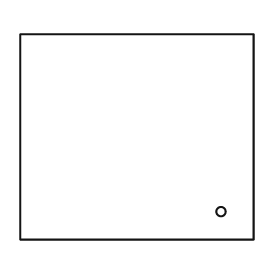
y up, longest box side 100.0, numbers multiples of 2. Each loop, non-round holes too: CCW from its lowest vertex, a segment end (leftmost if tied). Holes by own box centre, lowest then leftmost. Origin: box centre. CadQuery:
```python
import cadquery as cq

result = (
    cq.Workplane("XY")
    .moveTo(-50.0, -44.0)
    .lineTo(50.0, -44.0)
    .lineTo(50.0, 44.0)
    .lineTo(-50.0, 44.0)
    .close()
    .moveTo(36.0, -32.0)
    .circle(2.0)
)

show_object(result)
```